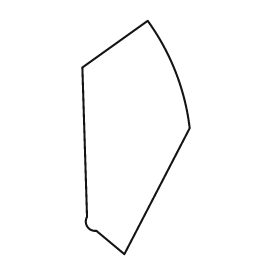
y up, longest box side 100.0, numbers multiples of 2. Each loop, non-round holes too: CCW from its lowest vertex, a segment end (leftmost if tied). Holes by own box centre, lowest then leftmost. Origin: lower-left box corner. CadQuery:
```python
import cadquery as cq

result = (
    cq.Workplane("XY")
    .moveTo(18.0, 0.0)
    .lineTo(46.0, 54.0)
    .threePointArc((40.0, 78.0), (28.0, 100.0))
    .lineTo(0.0, 80.0)
    .lineTo(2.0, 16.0)
    .threePointArc((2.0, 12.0), (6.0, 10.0))
    .close()
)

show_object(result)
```